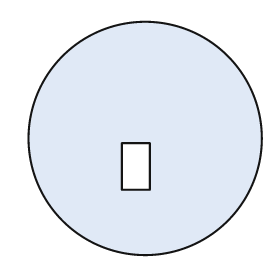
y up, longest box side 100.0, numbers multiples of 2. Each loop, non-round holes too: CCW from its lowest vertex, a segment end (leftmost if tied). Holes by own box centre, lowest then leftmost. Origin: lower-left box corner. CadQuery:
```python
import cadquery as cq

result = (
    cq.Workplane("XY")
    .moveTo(50.0, 50.0)
    .circle(50.0)
    .moveTo(40.0, 28.0)
    .lineTo(52.0, 28.0)
    .lineTo(52.0, 48.0)
    .lineTo(40.0, 48.0)
    .close()
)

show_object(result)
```